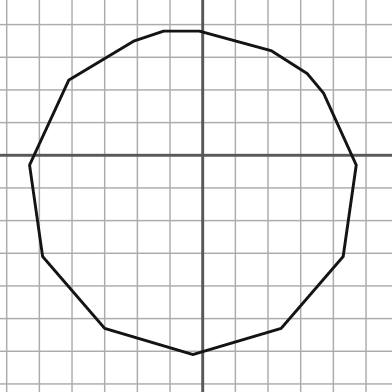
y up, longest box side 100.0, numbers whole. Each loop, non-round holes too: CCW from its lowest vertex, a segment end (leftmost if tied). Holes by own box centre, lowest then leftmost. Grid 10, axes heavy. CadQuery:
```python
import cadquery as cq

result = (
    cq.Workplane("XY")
    .moveTo(-3.0, -61.0)
    .lineTo(24.0, -53.0)
    .lineTo(43.0, -31.0)
    .lineTo(47.0, -3.0)
    .lineTo(37.0, 19.0)
    .lineTo(32.0, 25.0)
    .lineTo(21.0, 32.0)
    .lineTo(-1.0, 38.0)
    .lineTo(-12.0, 38.0)
    .lineTo(-21.0, 35.0)
    .lineTo(-41.0, 23.0)
    .lineTo(-53.0, -3.0)
    .lineTo(-49.0, -31.0)
    .lineTo(-30.0, -53.0)
    .close()
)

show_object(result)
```